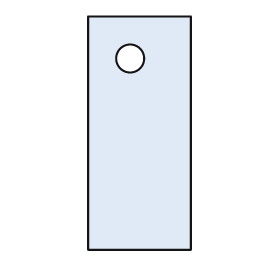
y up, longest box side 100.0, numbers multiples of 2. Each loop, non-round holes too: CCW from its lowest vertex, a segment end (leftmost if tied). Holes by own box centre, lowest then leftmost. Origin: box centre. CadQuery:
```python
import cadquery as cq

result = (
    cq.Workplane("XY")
    .moveTo(-22.0, -50.0)
    .lineTo(22.0, -50.0)
    .lineTo(22.0, 50.0)
    .lineTo(-22.0, 50.0)
    .close()
    .moveTo(-4.0, 32.0)
    .circle(6.0)
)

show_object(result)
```